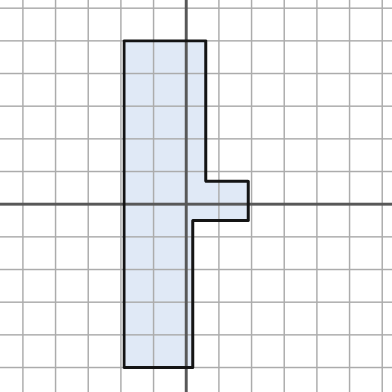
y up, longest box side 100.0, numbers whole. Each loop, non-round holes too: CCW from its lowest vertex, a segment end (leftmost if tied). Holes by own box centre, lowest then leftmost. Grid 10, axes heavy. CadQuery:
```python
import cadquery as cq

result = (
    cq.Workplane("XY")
    .moveTo(-19.0, -50.0)
    .lineTo(2.0, -50.0)
    .lineTo(2.0, -5.0)
    .lineTo(19.0, -5.0)
    .lineTo(19.0, 7.0)
    .lineTo(6.0, 7.0)
    .lineTo(6.0, 50.0)
    .lineTo(-19.0, 50.0)
    .close()
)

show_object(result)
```